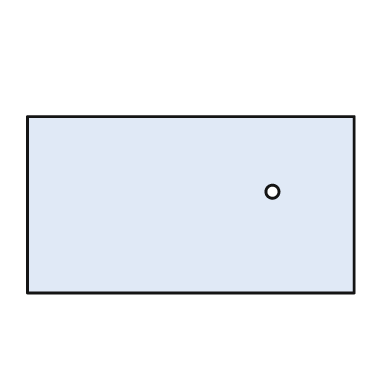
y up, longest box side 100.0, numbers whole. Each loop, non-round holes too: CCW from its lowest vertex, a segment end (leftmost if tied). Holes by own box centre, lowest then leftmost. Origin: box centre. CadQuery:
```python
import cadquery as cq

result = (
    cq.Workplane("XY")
    .moveTo(-50.0, -27.0)
    .lineTo(50.0, -27.0)
    .lineTo(50.0, 27.0)
    .lineTo(-50.0, 27.0)
    .close()
    .moveTo(25.0, 4.0)
    .circle(2.0)
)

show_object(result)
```